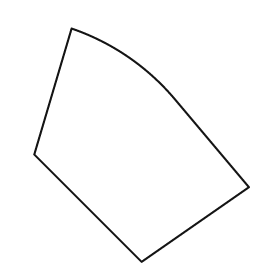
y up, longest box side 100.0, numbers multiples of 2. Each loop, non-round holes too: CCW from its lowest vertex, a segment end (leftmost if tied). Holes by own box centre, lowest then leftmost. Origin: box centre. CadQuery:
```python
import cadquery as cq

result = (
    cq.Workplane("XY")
    .moveTo(0.0, -50.0)
    .lineTo(46.0, -18.0)
    .lineTo(14.0, 20.0)
    .threePointArc((-6.0, 38.0), (-30.0, 50.0))
    .lineTo(-46.0, -4.0)
    .close()
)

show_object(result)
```